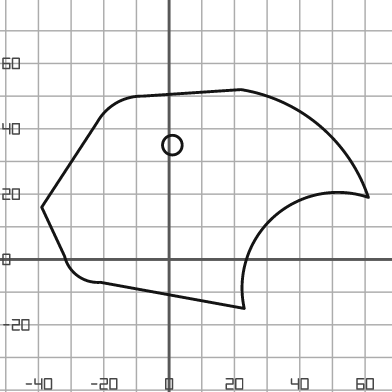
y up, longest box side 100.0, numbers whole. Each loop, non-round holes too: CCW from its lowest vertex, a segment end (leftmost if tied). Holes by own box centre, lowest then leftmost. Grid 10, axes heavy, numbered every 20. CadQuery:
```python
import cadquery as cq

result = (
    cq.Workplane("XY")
    .moveTo(23.0, -15.0)
    .threePointArc((32.0, 13.0), (61.0, 19.0))
    .threePointArc((46.0, 41.0), (22.0, 52.0))
    .lineTo(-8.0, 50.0)
    .threePointArc((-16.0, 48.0), (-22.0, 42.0))
    .lineTo(-39.0, 16.0)
    .lineTo(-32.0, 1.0)
    .threePointArc((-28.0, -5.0), (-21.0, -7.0))
    .close()
    .moveTo(1.0, 35.0)
    .circle(3.0)
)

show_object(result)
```